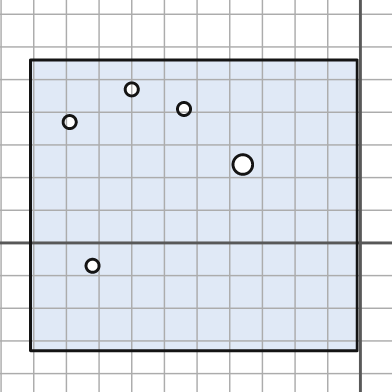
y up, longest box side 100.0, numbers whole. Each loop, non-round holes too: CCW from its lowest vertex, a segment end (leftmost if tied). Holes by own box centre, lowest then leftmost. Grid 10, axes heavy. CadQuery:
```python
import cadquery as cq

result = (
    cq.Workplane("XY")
    .moveTo(-101.0, -33.0)
    .lineTo(-1.0, -33.0)
    .lineTo(-1.0, 56.0)
    .lineTo(-101.0, 56.0)
    .close()
    .moveTo(-82.0, -7.0)
    .circle(2.0)
    .moveTo(-36.0, 24.0)
    .circle(3.0)
    .moveTo(-89.0, 37.0)
    .circle(2.0)
    .moveTo(-54.0, 41.0)
    .circle(2.0)
    .moveTo(-70.0, 47.0)
    .circle(2.0)
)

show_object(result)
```